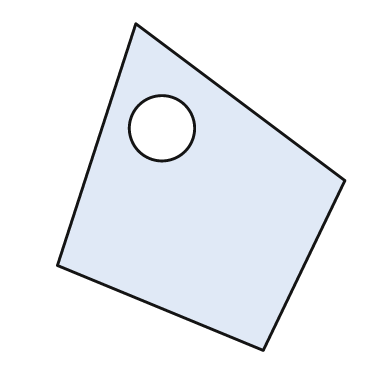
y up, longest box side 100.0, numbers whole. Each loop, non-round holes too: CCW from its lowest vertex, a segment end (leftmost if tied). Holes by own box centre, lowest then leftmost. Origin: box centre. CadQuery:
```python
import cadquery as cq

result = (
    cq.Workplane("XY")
    .moveTo(19.0, -50.0)
    .lineTo(44.0, 2.0)
    .lineTo(-20.0, 50.0)
    .lineTo(-44.0, -24.0)
    .close()
    .moveTo(-12.0, 18.0)
    .circle(10.0)
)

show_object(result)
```